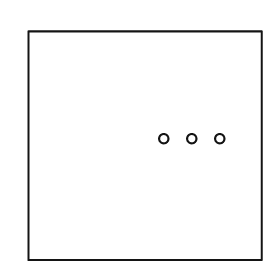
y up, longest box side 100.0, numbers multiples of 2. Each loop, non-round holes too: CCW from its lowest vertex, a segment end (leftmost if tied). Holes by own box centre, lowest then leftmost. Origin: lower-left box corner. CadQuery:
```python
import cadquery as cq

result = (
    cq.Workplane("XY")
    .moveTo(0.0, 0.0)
    .lineTo(100.0, 0.0)
    .lineTo(100.0, 98.0)
    .lineTo(0.0, 98.0)
    .close()
    .moveTo(58.0, 52.0)
    .circle(2.0)
    .moveTo(70.0, 52.0)
    .circle(2.0)
    .moveTo(82.0, 52.0)
    .circle(2.0)
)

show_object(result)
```